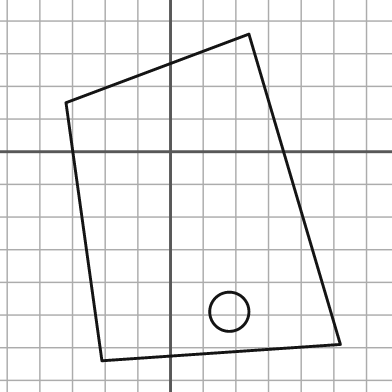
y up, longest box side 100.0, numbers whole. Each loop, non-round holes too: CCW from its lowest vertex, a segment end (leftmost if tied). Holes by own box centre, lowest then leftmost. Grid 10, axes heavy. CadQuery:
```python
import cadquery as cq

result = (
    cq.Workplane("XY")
    .moveTo(-21.0, -64.0)
    .lineTo(52.0, -59.0)
    .lineTo(24.0, 36.0)
    .lineTo(-32.0, 15.0)
    .close()
    .moveTo(18.0, -49.0)
    .circle(6.0)
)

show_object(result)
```